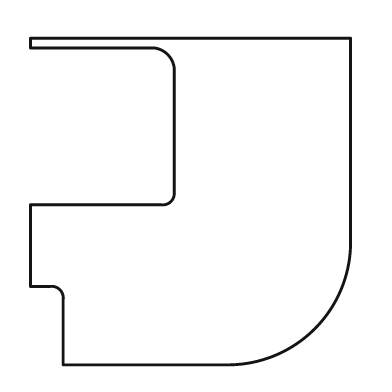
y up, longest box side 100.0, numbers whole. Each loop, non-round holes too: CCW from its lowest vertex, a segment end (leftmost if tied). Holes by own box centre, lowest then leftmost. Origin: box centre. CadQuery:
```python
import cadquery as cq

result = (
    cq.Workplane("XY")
    .moveTo(-39.0, -50.0)
    .lineTo(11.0, -50.0)
    .threePointArc((38.0, -39.0), (49.0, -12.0))
    .lineTo(49.0, 50.0)
    .lineTo(-49.0, 50.0)
    .lineTo(-49.0, 47.0)
    .lineTo(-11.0, 47.0)
    .threePointArc((-7.0, 45.0), (-5.0, 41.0))
    .lineTo(-5.0, 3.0)
    .threePointArc((-6.0, 0.0), (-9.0, -1.0))
    .lineTo(-49.0, -1.0)
    .lineTo(-49.0, -26.0)
    .lineTo(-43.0, -26.0)
    .threePointArc((-40.0, -27.0), (-39.0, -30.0))
    .close()
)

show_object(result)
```